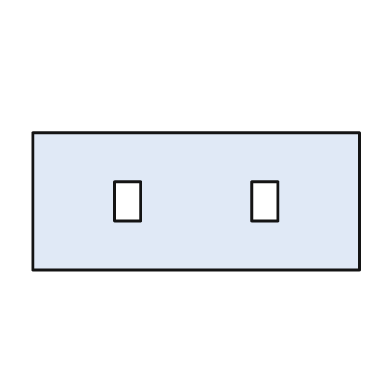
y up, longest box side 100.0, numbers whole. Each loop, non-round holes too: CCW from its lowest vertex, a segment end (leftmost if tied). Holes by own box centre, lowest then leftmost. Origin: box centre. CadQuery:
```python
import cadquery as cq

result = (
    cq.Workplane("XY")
    .moveTo(-50.0, -21.0)
    .lineTo(50.0, -21.0)
    .lineTo(50.0, 21.0)
    .lineTo(-50.0, 21.0)
    .close()
    .moveTo(-25.0, -6.0)
    .lineTo(-17.0, -6.0)
    .lineTo(-17.0, 6.0)
    .lineTo(-25.0, 6.0)
    .close()
    .moveTo(17.0, -6.0)
    .lineTo(25.0, -6.0)
    .lineTo(25.0, 6.0)
    .lineTo(17.0, 6.0)
    .close()
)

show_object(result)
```